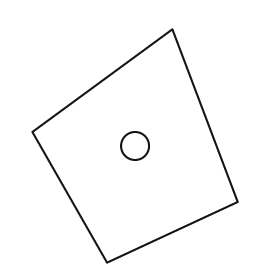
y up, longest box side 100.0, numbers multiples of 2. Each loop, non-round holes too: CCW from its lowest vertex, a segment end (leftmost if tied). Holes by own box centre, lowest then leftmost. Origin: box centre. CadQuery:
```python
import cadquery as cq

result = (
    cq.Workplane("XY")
    .moveTo(-12.0, -50.0)
    .lineTo(44.0, -24.0)
    .lineTo(16.0, 50.0)
    .lineTo(-44.0, 6.0)
    .close()
    .moveTo(0.0, 0.0)
    .circle(6.0)
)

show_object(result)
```